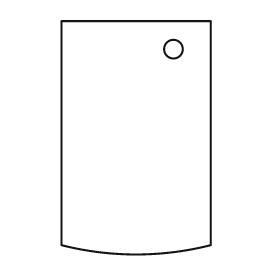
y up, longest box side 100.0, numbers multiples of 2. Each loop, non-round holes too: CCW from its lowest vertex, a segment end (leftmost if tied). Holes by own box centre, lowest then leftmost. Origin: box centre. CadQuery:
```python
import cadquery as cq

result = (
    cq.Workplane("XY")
    .moveTo(-32.0, -46.0)
    .threePointArc((0.0, -50.0), (32.0, -46.0))
    .lineTo(32.0, 50.0)
    .lineTo(-32.0, 50.0)
    .close()
    .moveTo(16.0, 38.0)
    .circle(4.0)
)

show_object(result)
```